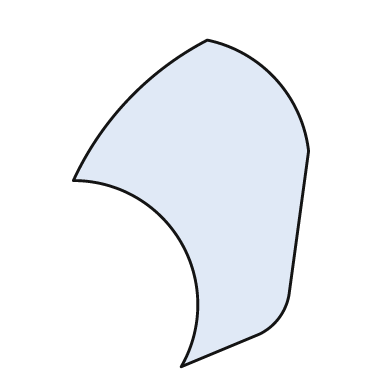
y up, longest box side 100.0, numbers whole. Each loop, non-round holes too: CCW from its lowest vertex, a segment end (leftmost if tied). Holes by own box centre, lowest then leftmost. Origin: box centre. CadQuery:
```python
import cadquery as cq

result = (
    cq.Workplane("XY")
    .moveTo(-3.0, -50.0)
    .lineTo(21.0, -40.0)
    .threePointArc((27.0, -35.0), (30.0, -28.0))
    .lineTo(36.0, 16.0)
    .threePointArc((26.0, 38.0), (5.0, 50.0))
    .threePointArc((-19.0, 32.0), (-36.0, 7.0))
    .threePointArc((-3.0, -12.0), (-3.0, -50.0))
    .close()
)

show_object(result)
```